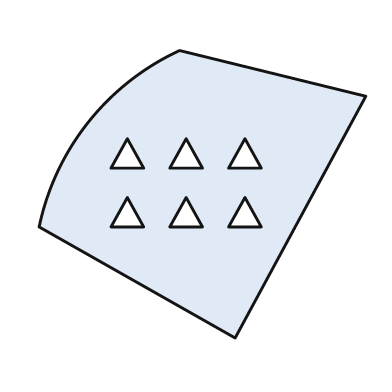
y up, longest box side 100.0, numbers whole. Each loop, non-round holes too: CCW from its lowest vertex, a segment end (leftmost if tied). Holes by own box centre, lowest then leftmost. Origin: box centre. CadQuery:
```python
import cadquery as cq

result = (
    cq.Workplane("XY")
    .moveTo(10.0, -44.0)
    .lineTo(50.0, 30.0)
    .lineTo(-7.0, 44.0)
    .threePointArc((-35.0, 22.0), (-50.0, -10.0))
    .close()
    .moveTo(-28.0, -10.0)
    .lineTo(-18.0, -10.0)
    .lineTo(-23.0, -1.0)
    .close()
    .moveTo(-10.0, -10.0)
    .lineTo(0.0, -10.0)
    .lineTo(-5.0, -1.0)
    .close()
    .moveTo(8.0, -10.0)
    .lineTo(18.0, -10.0)
    .lineTo(13.0, -1.0)
    .close()
    .moveTo(-28.0, 8.0)
    .lineTo(-18.0, 8.0)
    .lineTo(-23.0, 17.0)
    .close()
    .moveTo(-10.0, 8.0)
    .lineTo(0.0, 8.0)
    .lineTo(-5.0, 17.0)
    .close()
    .moveTo(8.0, 8.0)
    .lineTo(18.0, 8.0)
    .lineTo(13.0, 17.0)
    .close()
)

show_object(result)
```